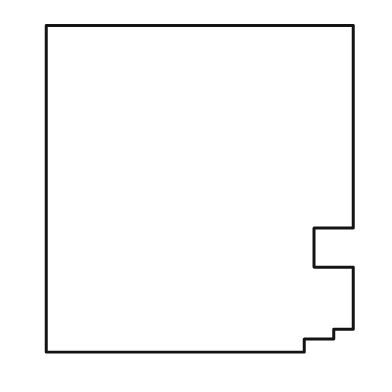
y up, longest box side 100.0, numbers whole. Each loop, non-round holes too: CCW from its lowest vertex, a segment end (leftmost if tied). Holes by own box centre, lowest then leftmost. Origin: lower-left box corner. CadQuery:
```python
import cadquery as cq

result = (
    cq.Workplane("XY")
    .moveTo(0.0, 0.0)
    .lineTo(79.0, 0.0)
    .lineTo(79.0, 4.0)
    .lineTo(88.0, 4.0)
    .lineTo(88.0, 7.0)
    .lineTo(94.0, 7.0)
    .lineTo(94.0, 26.0)
    .lineTo(82.0, 26.0)
    .lineTo(82.0, 38.0)
    .lineTo(94.0, 38.0)
    .lineTo(94.0, 100.0)
    .lineTo(0.0, 100.0)
    .close()
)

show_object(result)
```